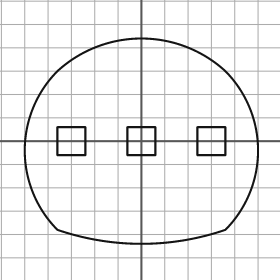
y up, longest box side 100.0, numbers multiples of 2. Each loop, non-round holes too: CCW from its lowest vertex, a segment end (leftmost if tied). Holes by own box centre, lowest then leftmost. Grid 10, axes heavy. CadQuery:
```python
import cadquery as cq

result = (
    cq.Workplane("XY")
    .moveTo(-36.0, -38.0)
    .threePointArc((0.0, -44.0), (36.0, -38.0))
    .threePointArc((50.0, -4.0), (36.0, 30.0))
    .threePointArc((0.0, 44.0), (-36.0, 30.0))
    .threePointArc((-50.0, -4.0), (-36.0, -38.0))
    .close()
    .moveTo(-36.0, -6.0)
    .lineTo(-24.0, -6.0)
    .lineTo(-24.0, 6.0)
    .lineTo(-36.0, 6.0)
    .close()
    .moveTo(-6.0, -6.0)
    .lineTo(6.0, -6.0)
    .lineTo(6.0, 6.0)
    .lineTo(-6.0, 6.0)
    .close()
    .moveTo(24.0, -6.0)
    .lineTo(36.0, -6.0)
    .lineTo(36.0, 6.0)
    .lineTo(24.0, 6.0)
    .close()
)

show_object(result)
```